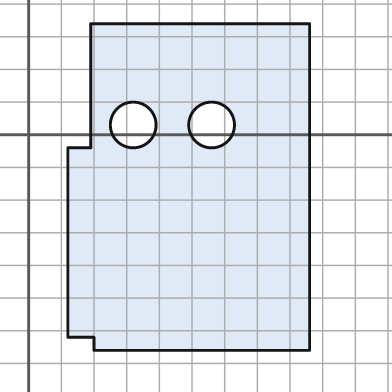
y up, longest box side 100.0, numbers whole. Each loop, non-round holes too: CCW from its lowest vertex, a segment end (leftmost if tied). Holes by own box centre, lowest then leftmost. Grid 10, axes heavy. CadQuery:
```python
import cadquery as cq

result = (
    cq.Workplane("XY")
    .moveTo(20.0, -66.0)
    .lineTo(86.0, -66.0)
    .lineTo(86.0, 34.0)
    .lineTo(19.0, 34.0)
    .lineTo(19.0, -4.0)
    .lineTo(12.0, -4.0)
    .lineTo(12.0, -62.0)
    .lineTo(20.0, -62.0)
    .close()
    .moveTo(32.0, 3.0)
    .circle(7.0)
    .moveTo(56.0, 3.0)
    .circle(7.0)
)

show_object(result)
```